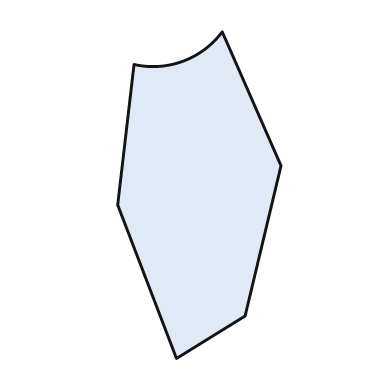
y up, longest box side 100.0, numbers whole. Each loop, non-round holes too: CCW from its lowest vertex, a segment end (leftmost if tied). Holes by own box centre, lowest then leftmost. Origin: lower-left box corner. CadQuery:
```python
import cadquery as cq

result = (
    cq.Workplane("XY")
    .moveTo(18.0, 0.0)
    .lineTo(39.0, 13.0)
    .lineTo(50.0, 59.0)
    .lineTo(32.0, 100.0)
    .threePointArc((20.0, 91.0), (5.0, 90.0))
    .lineTo(0.0, 47.0)
    .close()
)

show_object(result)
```